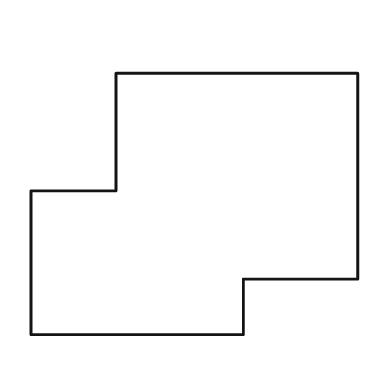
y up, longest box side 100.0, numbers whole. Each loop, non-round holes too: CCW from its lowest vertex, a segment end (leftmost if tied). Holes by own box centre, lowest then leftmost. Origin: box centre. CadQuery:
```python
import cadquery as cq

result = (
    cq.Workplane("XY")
    .moveTo(-50.0, -40.0)
    .lineTo(15.0, -40.0)
    .lineTo(15.0, -23.0)
    .lineTo(50.0, -23.0)
    .lineTo(50.0, 40.0)
    .lineTo(-24.0, 40.0)
    .lineTo(-24.0, 4.0)
    .lineTo(-50.0, 4.0)
    .close()
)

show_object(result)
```